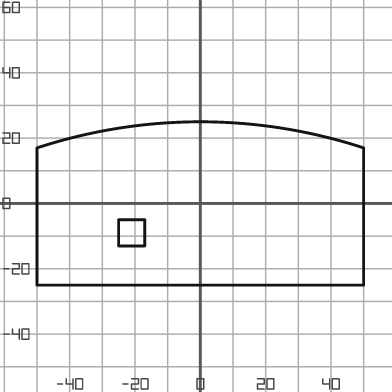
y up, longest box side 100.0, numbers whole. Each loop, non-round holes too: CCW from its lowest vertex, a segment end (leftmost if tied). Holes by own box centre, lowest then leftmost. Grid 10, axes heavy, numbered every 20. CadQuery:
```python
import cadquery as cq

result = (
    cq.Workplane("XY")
    .moveTo(-50.0, -25.0)
    .lineTo(50.0, -25.0)
    .lineTo(50.0, 17.0)
    .threePointArc((0.0, 25.0), (-50.0, 17.0))
    .close()
    .moveTo(-25.0, -13.0)
    .lineTo(-17.0, -13.0)
    .lineTo(-17.0, -5.0)
    .lineTo(-25.0, -5.0)
    .close()
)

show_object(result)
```